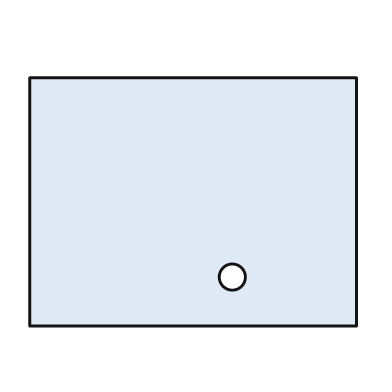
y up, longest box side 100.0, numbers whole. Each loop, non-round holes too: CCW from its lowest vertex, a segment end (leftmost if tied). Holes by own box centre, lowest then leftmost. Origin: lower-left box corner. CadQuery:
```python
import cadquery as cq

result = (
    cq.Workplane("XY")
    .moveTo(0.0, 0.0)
    .lineTo(100.0, 0.0)
    .lineTo(100.0, 76.0)
    .lineTo(0.0, 76.0)
    .close()
    .moveTo(62.0, 15.0)
    .circle(4.0)
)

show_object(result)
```